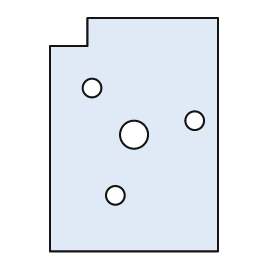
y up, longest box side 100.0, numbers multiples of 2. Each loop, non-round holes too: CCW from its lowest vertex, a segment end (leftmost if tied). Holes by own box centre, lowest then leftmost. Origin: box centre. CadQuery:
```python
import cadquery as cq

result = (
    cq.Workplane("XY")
    .moveTo(-36.0, -50.0)
    .lineTo(36.0, -50.0)
    .lineTo(36.0, 50.0)
    .lineTo(-20.0, 50.0)
    .lineTo(-20.0, 38.0)
    .lineTo(-36.0, 38.0)
    .close()
    .moveTo(-8.0, -26.0)
    .circle(4.0)
    .moveTo(0.0, 0.0)
    .circle(6.0)
    .moveTo(26.0, 6.0)
    .circle(4.0)
    .moveTo(-18.0, 20.0)
    .circle(4.0)
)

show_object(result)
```